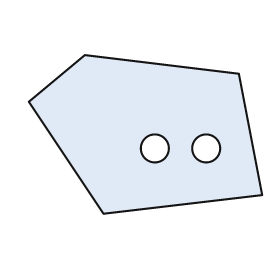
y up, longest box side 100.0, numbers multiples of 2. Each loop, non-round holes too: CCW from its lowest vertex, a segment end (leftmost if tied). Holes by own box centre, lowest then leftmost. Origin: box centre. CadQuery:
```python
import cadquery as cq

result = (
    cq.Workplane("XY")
    .moveTo(-18.0, -34.0)
    .lineTo(50.0, -26.0)
    .lineTo(40.0, 26.0)
    .lineTo(-26.0, 34.0)
    .lineTo(-50.0, 14.0)
    .close()
    .moveTo(4.0, -6.0)
    .circle(6.0)
    .moveTo(26.0, -6.0)
    .circle(6.0)
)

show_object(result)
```